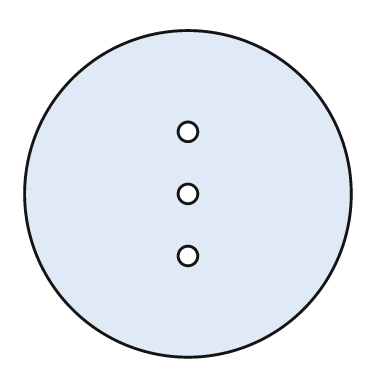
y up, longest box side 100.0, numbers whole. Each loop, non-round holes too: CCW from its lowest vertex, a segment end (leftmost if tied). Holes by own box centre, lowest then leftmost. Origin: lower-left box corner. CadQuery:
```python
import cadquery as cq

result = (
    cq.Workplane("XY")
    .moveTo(50.0, 50.0)
    .circle(50.0)
    .moveTo(50.0, 31.0)
    .circle(3.0)
    .moveTo(50.0, 50.0)
    .circle(3.0)
    .moveTo(50.0, 69.0)
    .circle(3.0)
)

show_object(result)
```